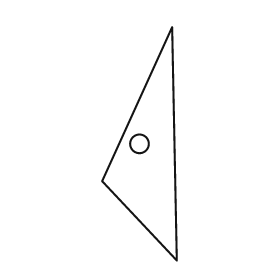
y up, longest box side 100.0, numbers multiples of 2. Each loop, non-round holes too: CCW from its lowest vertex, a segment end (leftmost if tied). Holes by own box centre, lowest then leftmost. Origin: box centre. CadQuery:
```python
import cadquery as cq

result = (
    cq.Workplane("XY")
    .moveTo(16.0, -50.0)
    .lineTo(14.0, 50.0)
    .lineTo(-16.0, -16.0)
    .close()
    .moveTo(0.0, 0.0)
    .circle(4.0)
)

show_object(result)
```